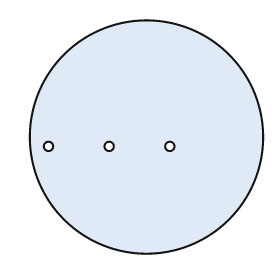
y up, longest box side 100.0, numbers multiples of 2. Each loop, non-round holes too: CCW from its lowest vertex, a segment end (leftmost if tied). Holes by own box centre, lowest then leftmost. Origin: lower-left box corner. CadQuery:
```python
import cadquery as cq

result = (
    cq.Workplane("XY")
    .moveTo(50.0, 50.0)
    .circle(50.0)
    .moveTo(8.0, 46.0)
    .circle(2.0)
    .moveTo(34.0, 46.0)
    .circle(2.0)
    .moveTo(60.0, 46.0)
    .circle(2.0)
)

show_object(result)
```